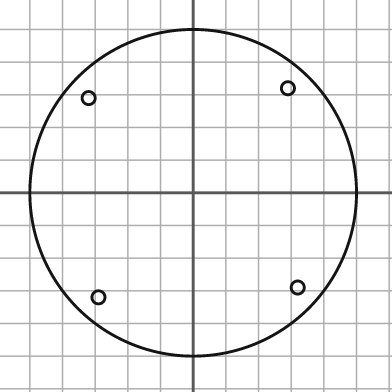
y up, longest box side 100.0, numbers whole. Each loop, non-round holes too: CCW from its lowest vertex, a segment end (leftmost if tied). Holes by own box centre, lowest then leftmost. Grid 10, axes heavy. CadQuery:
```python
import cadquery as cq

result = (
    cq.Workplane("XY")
    .moveTo(0.0, 0.0)
    .circle(50.0)
    .moveTo(-29.0, -32.0)
    .circle(2.0)
    .moveTo(32.0, -29.0)
    .circle(2.0)
    .moveTo(-32.0, 29.0)
    .circle(2.0)
    .moveTo(29.0, 32.0)
    .circle(2.0)
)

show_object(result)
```